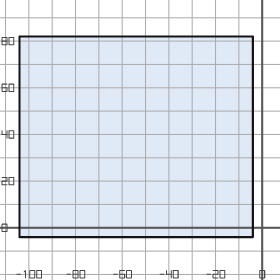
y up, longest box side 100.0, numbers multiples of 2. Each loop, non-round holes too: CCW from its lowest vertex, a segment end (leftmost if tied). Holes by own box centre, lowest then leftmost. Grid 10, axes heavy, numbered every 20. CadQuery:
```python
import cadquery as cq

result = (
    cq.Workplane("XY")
    .moveTo(-104.0, -4.0)
    .lineTo(-4.0, -4.0)
    .lineTo(-4.0, 82.0)
    .lineTo(-104.0, 82.0)
    .close()
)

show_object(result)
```